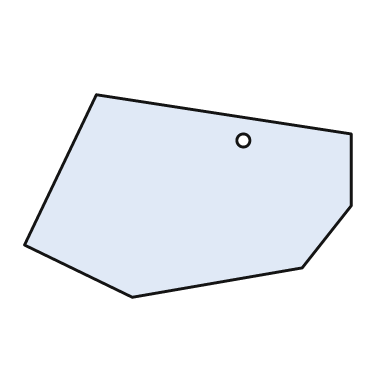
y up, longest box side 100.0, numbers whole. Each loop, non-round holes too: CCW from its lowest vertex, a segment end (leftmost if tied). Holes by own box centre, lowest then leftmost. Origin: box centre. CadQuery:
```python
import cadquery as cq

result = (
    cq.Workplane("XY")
    .moveTo(-17.0, -31.0)
    .lineTo(35.0, -22.0)
    .lineTo(50.0, -3.0)
    .lineTo(50.0, 19.0)
    .lineTo(-28.0, 31.0)
    .lineTo(-50.0, -15.0)
    .close()
    .moveTo(17.0, 17.0)
    .circle(2.0)
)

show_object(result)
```